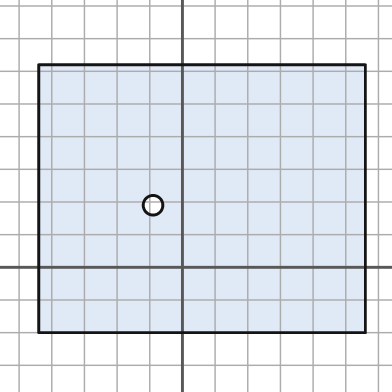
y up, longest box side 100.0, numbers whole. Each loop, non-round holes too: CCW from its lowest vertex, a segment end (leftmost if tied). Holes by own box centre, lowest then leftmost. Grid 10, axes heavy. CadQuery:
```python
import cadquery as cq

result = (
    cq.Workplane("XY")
    .moveTo(-44.0, -20.0)
    .lineTo(56.0, -20.0)
    .lineTo(56.0, 62.0)
    .lineTo(-44.0, 62.0)
    .close()
    .moveTo(-9.0, 19.0)
    .circle(3.0)
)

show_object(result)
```